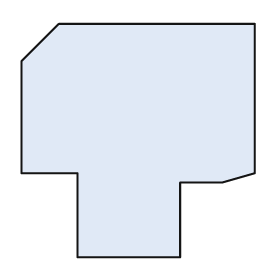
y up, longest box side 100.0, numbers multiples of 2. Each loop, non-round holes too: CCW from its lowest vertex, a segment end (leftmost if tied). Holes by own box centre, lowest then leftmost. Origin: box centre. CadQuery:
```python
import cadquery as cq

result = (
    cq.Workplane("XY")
    .moveTo(-26.0, -50.0)
    .lineTo(18.0, -50.0)
    .lineTo(18.0, -18.0)
    .lineTo(36.0, -18.0)
    .lineTo(50.0, -14.0)
    .lineTo(50.0, 50.0)
    .lineTo(-34.0, 50.0)
    .lineTo(-50.0, 34.0)
    .lineTo(-50.0, -14.0)
    .lineTo(-26.0, -14.0)
    .close()
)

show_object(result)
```